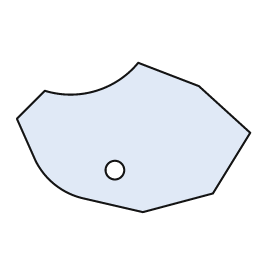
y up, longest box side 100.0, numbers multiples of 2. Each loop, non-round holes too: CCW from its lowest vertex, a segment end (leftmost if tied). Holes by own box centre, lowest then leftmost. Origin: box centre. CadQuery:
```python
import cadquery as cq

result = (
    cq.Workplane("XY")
    .moveTo(4.0, -32.0)
    .lineTo(34.0, -24.0)
    .lineTo(50.0, 2.0)
    .lineTo(28.0, 22.0)
    .lineTo(2.0, 32.0)
    .threePointArc((-16.0, 20.0), (-38.0, 20.0))
    .lineTo(-50.0, 8.0)
    .lineTo(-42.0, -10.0)
    .threePointArc((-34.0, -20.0), (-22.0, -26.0))
    .close()
    .moveTo(-8.0, -14.0)
    .circle(4.0)
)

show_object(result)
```